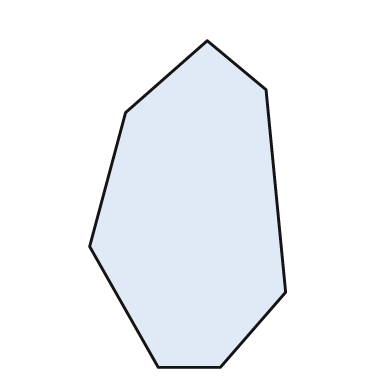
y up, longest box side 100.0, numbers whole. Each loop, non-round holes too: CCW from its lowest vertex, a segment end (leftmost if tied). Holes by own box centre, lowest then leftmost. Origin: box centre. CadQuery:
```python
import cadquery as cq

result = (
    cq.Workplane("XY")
    .moveTo(-9.0, -50.0)
    .lineTo(10.0, -50.0)
    .lineTo(30.0, -27.0)
    .lineTo(24.0, 35.0)
    .lineTo(6.0, 50.0)
    .lineTo(-19.0, 28.0)
    .lineTo(-30.0, -13.0)
    .close()
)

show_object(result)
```